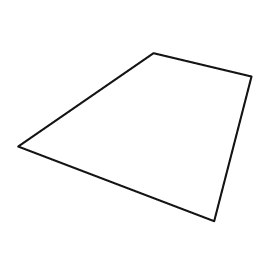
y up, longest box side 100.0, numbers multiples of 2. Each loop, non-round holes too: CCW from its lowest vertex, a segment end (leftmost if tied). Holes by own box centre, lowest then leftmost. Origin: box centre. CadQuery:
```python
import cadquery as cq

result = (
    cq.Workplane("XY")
    .moveTo(34.0, -36.0)
    .lineTo(50.0, 26.0)
    .lineTo(8.0, 36.0)
    .lineTo(-50.0, -4.0)
    .close()
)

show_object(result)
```